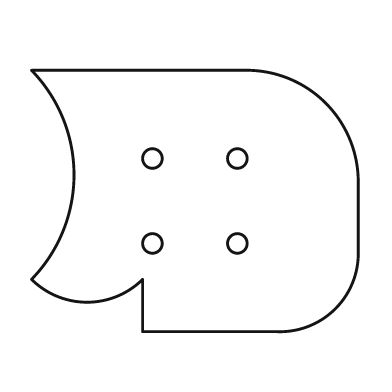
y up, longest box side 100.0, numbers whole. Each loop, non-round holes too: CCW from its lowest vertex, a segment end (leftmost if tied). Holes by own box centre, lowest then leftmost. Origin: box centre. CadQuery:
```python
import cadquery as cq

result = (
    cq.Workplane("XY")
    .moveTo(-16.0, -40.0)
    .lineTo(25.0, -40.0)
    .threePointArc((43.0, -33.0), (50.0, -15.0))
    .lineTo(50.0, 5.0)
    .threePointArc((40.0, 30.0), (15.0, 40.0))
    .lineTo(-50.0, 40.0)
    .threePointArc((-37.0, 8.0), (-50.0, -24.0))
    .threePointArc((-33.0, -31.0), (-16.0, -24.0))
    .close()
    .moveTo(-13.0, -13.0)
    .circle(3.0)
    .moveTo(13.0, -13.0)
    .circle(3.0)
    .moveTo(-13.0, 13.0)
    .circle(3.0)
    .moveTo(13.0, 13.0)
    .circle(3.0)
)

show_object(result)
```